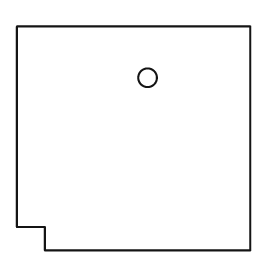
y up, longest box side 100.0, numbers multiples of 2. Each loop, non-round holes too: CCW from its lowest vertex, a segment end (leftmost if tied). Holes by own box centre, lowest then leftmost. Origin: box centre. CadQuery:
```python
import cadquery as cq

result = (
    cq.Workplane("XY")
    .moveTo(-38.0, -48.0)
    .lineTo(50.0, -48.0)
    .lineTo(50.0, 48.0)
    .lineTo(-50.0, 48.0)
    .lineTo(-50.0, -38.0)
    .lineTo(-38.0, -38.0)
    .close()
    .moveTo(6.0, 26.0)
    .circle(4.0)
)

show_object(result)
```